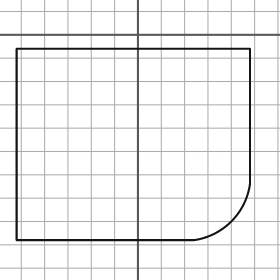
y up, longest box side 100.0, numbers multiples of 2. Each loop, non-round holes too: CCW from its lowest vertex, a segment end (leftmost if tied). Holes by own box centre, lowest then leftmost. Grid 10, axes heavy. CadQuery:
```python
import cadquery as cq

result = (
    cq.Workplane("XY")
    .moveTo(-52.0, -88.0)
    .lineTo(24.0, -88.0)
    .threePointArc((40.0, -80.0), (48.0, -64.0))
    .lineTo(48.0, -6.0)
    .lineTo(-52.0, -6.0)
    .close()
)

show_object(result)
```